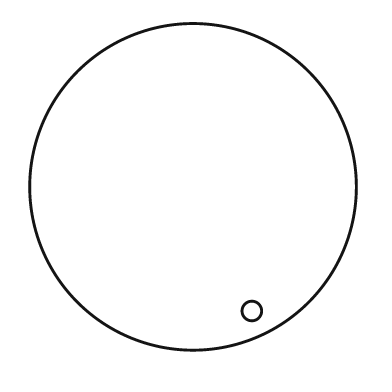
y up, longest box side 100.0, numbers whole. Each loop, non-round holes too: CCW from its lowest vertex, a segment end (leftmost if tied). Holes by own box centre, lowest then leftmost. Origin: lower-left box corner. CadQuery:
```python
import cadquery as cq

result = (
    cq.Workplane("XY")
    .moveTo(50.0, 50.0)
    .circle(50.0)
    .moveTo(68.0, 12.0)
    .circle(3.0)
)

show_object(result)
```